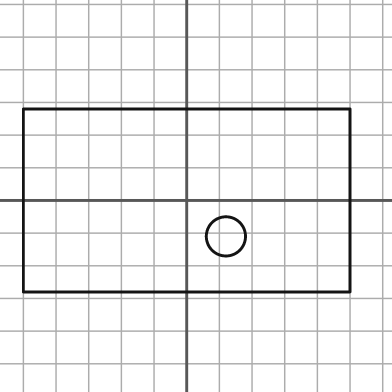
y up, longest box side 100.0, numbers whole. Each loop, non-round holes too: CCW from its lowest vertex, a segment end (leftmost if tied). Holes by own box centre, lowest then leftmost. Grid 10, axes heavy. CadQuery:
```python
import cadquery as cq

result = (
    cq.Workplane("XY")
    .moveTo(-50.0, -28.0)
    .lineTo(50.0, -28.0)
    .lineTo(50.0, 28.0)
    .lineTo(-50.0, 28.0)
    .close()
    .moveTo(12.0, -11.0)
    .circle(6.0)
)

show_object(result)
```